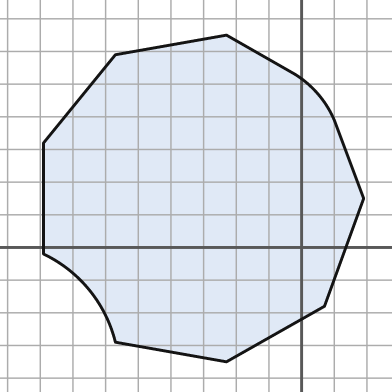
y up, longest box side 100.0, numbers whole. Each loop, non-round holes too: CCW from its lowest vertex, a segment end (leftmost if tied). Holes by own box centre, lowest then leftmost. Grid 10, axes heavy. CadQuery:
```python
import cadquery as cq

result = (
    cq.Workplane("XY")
    .moveTo(-23.0, -35.0)
    .lineTo(7.0, -18.0)
    .lineTo(19.0, 15.0)
    .lineTo(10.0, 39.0)
    .threePointArc((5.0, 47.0), (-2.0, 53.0))
    .lineTo(-23.0, 65.0)
    .lineTo(-57.0, 59.0)
    .lineTo(-79.0, 32.0)
    .lineTo(-79.0, -2.0)
    .threePointArc((-65.0, -13.0), (-57.0, -29.0))
    .close()
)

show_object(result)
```